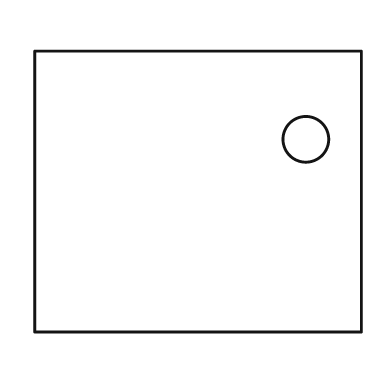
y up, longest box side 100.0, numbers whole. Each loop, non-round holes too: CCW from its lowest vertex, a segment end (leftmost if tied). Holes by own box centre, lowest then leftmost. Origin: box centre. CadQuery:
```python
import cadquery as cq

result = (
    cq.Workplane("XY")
    .moveTo(-50.0, -43.0)
    .lineTo(50.0, -43.0)
    .lineTo(50.0, 43.0)
    .lineTo(-50.0, 43.0)
    .close()
    .moveTo(33.0, 16.0)
    .circle(7.0)
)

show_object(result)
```